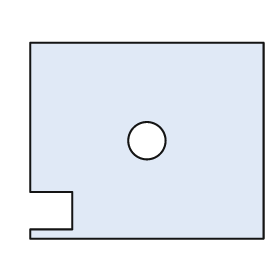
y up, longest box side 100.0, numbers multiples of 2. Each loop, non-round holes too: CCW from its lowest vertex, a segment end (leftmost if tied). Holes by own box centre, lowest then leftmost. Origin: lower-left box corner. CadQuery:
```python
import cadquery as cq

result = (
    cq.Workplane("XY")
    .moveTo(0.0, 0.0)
    .lineTo(100.0, 0.0)
    .lineTo(100.0, 84.0)
    .lineTo(0.0, 84.0)
    .lineTo(0.0, 20.0)
    .lineTo(18.0, 20.0)
    .lineTo(18.0, 4.0)
    .lineTo(0.0, 4.0)
    .close()
    .moveTo(50.0, 42.0)
    .circle(8.0)
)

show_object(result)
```